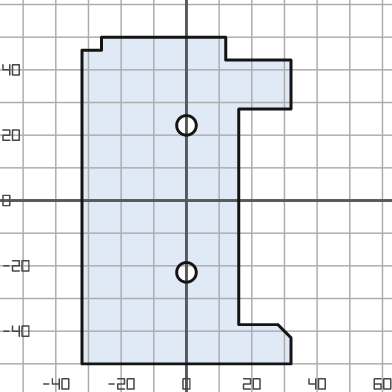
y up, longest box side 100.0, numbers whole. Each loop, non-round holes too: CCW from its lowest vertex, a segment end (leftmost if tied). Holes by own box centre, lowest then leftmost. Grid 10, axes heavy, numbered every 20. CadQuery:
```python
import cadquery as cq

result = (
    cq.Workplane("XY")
    .moveTo(-32.0, -50.0)
    .lineTo(32.0, -50.0)
    .lineTo(32.0, -42.0)
    .lineTo(28.0, -38.0)
    .lineTo(16.0, -38.0)
    .lineTo(16.0, 28.0)
    .lineTo(32.0, 28.0)
    .lineTo(32.0, 43.0)
    .lineTo(12.0, 43.0)
    .lineTo(12.0, 50.0)
    .lineTo(-26.0, 50.0)
    .lineTo(-26.0, 46.0)
    .lineTo(-32.0, 46.0)
    .close()
    .moveTo(0.0, -22.0)
    .circle(3.0)
    .moveTo(0.0, 23.0)
    .circle(3.0)
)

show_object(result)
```